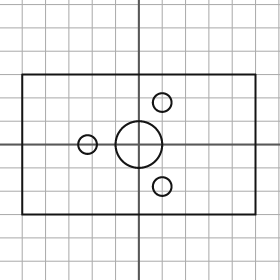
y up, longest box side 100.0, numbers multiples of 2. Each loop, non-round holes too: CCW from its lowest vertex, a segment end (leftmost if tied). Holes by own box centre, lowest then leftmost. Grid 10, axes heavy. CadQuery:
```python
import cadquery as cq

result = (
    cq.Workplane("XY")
    .moveTo(-50.0, -30.0)
    .lineTo(50.0, -30.0)
    .lineTo(50.0, 30.0)
    .lineTo(-50.0, 30.0)
    .close()
    .moveTo(10.0, -18.0)
    .circle(4.0)
    .moveTo(-22.0, 0.0)
    .circle(4.0)
    .moveTo(0.0, 0.0)
    .circle(10.0)
    .moveTo(10.0, 18.0)
    .circle(4.0)
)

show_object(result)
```